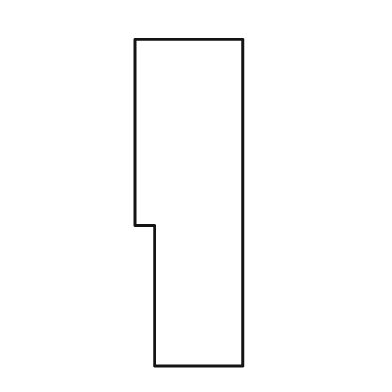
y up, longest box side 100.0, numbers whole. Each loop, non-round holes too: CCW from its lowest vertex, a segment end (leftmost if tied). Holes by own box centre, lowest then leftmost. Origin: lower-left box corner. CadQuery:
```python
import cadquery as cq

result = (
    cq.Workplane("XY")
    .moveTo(6.0, 0.0)
    .lineTo(33.0, 0.0)
    .lineTo(33.0, 100.0)
    .lineTo(0.0, 100.0)
    .lineTo(0.0, 43.0)
    .lineTo(6.0, 43.0)
    .close()
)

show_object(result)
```